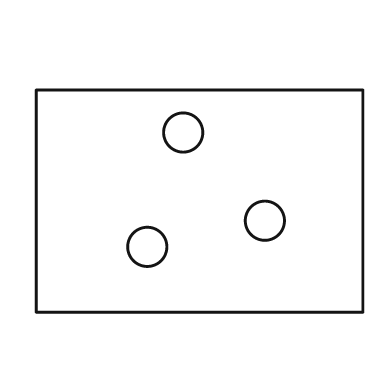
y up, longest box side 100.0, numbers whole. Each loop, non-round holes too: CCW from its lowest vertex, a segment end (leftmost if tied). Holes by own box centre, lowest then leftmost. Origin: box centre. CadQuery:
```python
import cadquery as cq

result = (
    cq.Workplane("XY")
    .moveTo(-50.0, -34.0)
    .lineTo(50.0, -34.0)
    .lineTo(50.0, 34.0)
    .lineTo(-50.0, 34.0)
    .close()
    .moveTo(-16.0, -14.0)
    .circle(6.0)
    .moveTo(20.0, -6.0)
    .circle(6.0)
    .moveTo(-5.0, 21.0)
    .circle(6.0)
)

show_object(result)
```